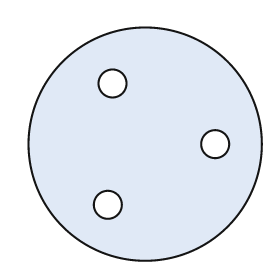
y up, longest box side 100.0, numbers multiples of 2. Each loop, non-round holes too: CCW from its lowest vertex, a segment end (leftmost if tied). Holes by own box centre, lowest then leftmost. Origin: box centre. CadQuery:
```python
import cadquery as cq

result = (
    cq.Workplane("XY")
    .moveTo(0.0, 0.0)
    .circle(50.0)
    .moveTo(-16.0, -26.0)
    .circle(6.0)
    .moveTo(30.0, 0.0)
    .circle(6.0)
    .moveTo(-14.0, 26.0)
    .circle(6.0)
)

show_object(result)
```